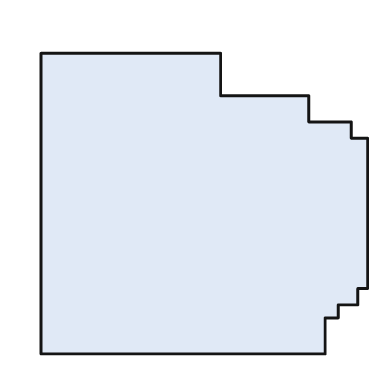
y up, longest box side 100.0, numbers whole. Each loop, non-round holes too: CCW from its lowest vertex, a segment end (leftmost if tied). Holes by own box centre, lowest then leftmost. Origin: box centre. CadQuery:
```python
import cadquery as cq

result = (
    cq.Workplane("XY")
    .moveTo(-50.0, -46.0)
    .lineTo(37.0, -46.0)
    .lineTo(37.0, -35.0)
    .lineTo(41.0, -35.0)
    .lineTo(41.0, -31.0)
    .lineTo(47.0, -31.0)
    .lineTo(47.0, -26.0)
    .lineTo(50.0, -26.0)
    .lineTo(50.0, 20.0)
    .lineTo(45.0, 20.0)
    .lineTo(45.0, 25.0)
    .lineTo(32.0, 25.0)
    .lineTo(32.0, 33.0)
    .lineTo(5.0, 33.0)
    .lineTo(5.0, 46.0)
    .lineTo(-50.0, 46.0)
    .close()
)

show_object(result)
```